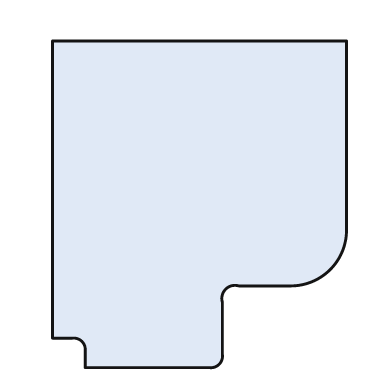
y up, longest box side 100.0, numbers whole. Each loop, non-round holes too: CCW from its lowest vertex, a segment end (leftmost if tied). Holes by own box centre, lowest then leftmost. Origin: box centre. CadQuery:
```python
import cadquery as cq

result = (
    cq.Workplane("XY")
    .moveTo(-35.0, -50.0)
    .lineTo(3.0, -50.0)
    .threePointArc((6.0, -49.0), (7.0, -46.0))
    .lineTo(7.0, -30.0)
    .threePointArc((8.0, -26.0), (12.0, -25.0))
    .lineTo(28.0, -25.0)
    .threePointArc((40.0, -20.0), (45.0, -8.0))
    .lineTo(45.0, 50.0)
    .lineTo(-45.0, 50.0)
    .lineTo(-45.0, -41.0)
    .lineTo(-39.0, -41.0)
    .threePointArc((-36.0, -42.0), (-35.0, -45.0))
    .close()
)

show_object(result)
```